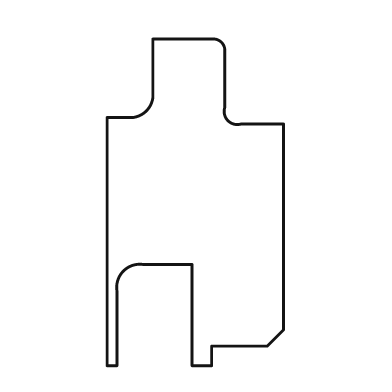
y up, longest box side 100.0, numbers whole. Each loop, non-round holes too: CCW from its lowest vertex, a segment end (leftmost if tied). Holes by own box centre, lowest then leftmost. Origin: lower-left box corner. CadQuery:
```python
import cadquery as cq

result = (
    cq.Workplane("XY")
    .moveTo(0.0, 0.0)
    .lineTo(3.0, 0.0)
    .lineTo(3.0, 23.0)
    .threePointArc((5.0, 29.0), (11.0, 31.0))
    .lineTo(26.0, 31.0)
    .lineTo(26.0, 0.0)
    .lineTo(32.0, 0.0)
    .lineTo(32.0, 6.0)
    .lineTo(49.0, 6.0)
    .lineTo(54.0, 11.0)
    .lineTo(54.0, 74.0)
    .lineTo(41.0, 74.0)
    .threePointArc((37.0, 75.0), (36.0, 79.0))
    .lineTo(36.0, 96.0)
    .threePointArc((35.0, 99.0), (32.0, 100.0))
    .lineTo(14.0, 100.0)
    .lineTo(14.0, 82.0)
    .threePointArc((12.0, 78.0), (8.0, 76.0))
    .lineTo(0.0, 76.0)
    .close()
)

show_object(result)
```